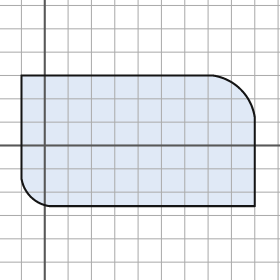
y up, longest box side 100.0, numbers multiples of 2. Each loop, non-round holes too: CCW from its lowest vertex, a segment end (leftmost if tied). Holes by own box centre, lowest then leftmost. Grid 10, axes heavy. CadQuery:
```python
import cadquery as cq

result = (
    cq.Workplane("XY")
    .moveTo(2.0, -26.0)
    .lineTo(90.0, -26.0)
    .lineTo(90.0, 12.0)
    .threePointArc((84.0, 24.0), (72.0, 30.0))
    .lineTo(-10.0, 30.0)
    .lineTo(-10.0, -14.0)
    .threePointArc((-6.0, -22.0), (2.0, -26.0))
    .close()
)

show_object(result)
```